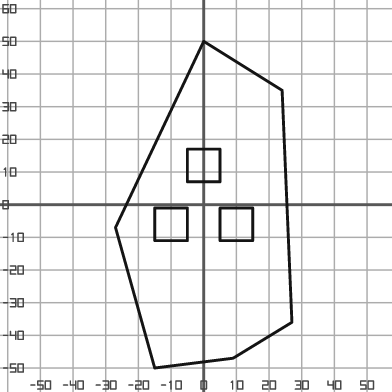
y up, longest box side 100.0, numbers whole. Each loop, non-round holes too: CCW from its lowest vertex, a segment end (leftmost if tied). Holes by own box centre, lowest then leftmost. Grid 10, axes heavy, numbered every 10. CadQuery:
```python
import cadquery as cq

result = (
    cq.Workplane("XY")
    .moveTo(-15.0, -50.0)
    .lineTo(9.0, -47.0)
    .lineTo(27.0, -36.0)
    .lineTo(24.0, 35.0)
    .lineTo(0.0, 50.0)
    .lineTo(-27.0, -7.0)
    .close()
    .moveTo(-15.0, -11.0)
    .lineTo(-5.0, -11.0)
    .lineTo(-5.0, -1.0)
    .lineTo(-15.0, -1.0)
    .close()
    .moveTo(5.0, -11.0)
    .lineTo(15.0, -11.0)
    .lineTo(15.0, -1.0)
    .lineTo(5.0, -1.0)
    .close()
    .moveTo(-5.0, 7.0)
    .lineTo(5.0, 7.0)
    .lineTo(5.0, 17.0)
    .lineTo(-5.0, 17.0)
    .close()
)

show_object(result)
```